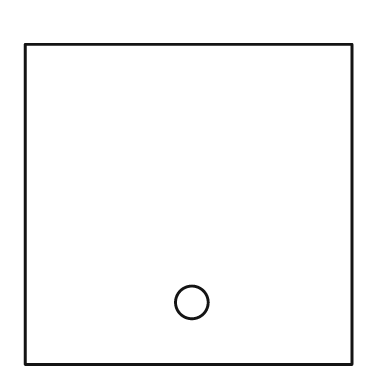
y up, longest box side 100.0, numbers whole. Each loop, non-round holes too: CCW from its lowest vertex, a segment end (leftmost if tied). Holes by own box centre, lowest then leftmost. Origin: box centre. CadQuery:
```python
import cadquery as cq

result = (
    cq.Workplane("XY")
    .moveTo(-50.0, -49.0)
    .lineTo(50.0, -49.0)
    .lineTo(50.0, 49.0)
    .lineTo(-50.0, 49.0)
    .close()
    .moveTo(1.0, -30.0)
    .circle(5.0)
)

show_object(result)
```